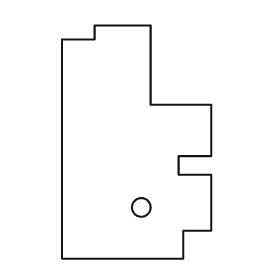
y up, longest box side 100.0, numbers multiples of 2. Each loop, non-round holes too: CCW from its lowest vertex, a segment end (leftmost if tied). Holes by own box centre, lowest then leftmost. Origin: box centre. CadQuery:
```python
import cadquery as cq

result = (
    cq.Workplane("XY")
    .moveTo(-32.0, -50.0)
    .lineTo(20.0, -50.0)
    .lineTo(20.0, -38.0)
    .lineTo(32.0, -38.0)
    .lineTo(32.0, -14.0)
    .lineTo(18.0, -14.0)
    .lineTo(18.0, -6.0)
    .lineTo(32.0, -6.0)
    .lineTo(32.0, 16.0)
    .lineTo(6.0, 16.0)
    .lineTo(6.0, 50.0)
    .lineTo(-18.0, 50.0)
    .lineTo(-18.0, 44.0)
    .lineTo(-32.0, 44.0)
    .close()
    .moveTo(2.0, -28.0)
    .circle(4.0)
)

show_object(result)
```